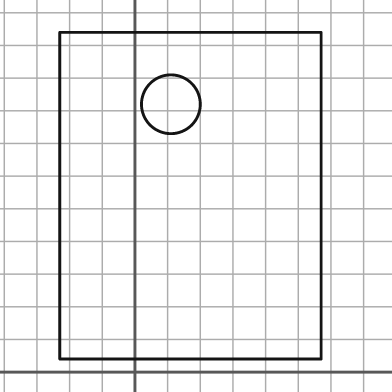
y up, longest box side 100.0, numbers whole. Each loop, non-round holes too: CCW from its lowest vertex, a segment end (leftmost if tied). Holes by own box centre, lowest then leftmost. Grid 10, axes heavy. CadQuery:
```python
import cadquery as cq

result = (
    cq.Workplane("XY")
    .moveTo(-23.0, 4.0)
    .lineTo(57.0, 4.0)
    .lineTo(57.0, 104.0)
    .lineTo(-23.0, 104.0)
    .close()
    .moveTo(11.0, 82.0)
    .circle(9.0)
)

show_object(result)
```